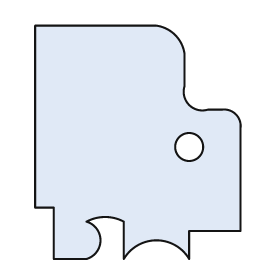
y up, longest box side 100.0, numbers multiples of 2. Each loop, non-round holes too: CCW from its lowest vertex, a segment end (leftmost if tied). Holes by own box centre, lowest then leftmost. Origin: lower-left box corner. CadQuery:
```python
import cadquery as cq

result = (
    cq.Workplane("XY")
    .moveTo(8.0, 0.0)
    .lineTo(22.0, 0.0)
    .threePointArc((28.0, 8.0), (22.0, 16.0))
    .threePointArc((30.0, 18.0), (38.0, 16.0))
    .lineTo(38.0, 0.0)
    .threePointArc((52.0, 8.0), (66.0, 0.0))
    .lineTo(66.0, 12.0)
    .lineTo(88.0, 12.0)
    .lineTo(88.0, 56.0)
    .threePointArc((86.0, 62.0), (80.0, 64.0))
    .lineTo(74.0, 64.0)
    .threePointArc((66.0, 66.0), (64.0, 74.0))
    .lineTo(64.0, 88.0)
    .threePointArc((60.0, 96.0), (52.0, 100.0))
    .lineTo(0.0, 100.0)
    .lineTo(0.0, 22.0)
    .lineTo(8.0, 22.0)
    .close()
    .moveTo(66.0, 48.0)
    .circle(6.0)
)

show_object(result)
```